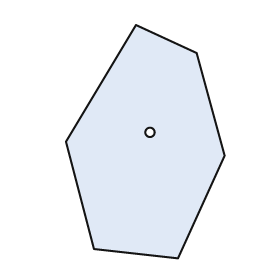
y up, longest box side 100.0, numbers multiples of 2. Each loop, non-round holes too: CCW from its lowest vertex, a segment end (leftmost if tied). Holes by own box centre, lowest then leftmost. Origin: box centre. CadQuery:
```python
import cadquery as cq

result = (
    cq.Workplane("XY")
    .moveTo(14.0, -50.0)
    .lineTo(34.0, -6.0)
    .lineTo(22.0, 38.0)
    .lineTo(-4.0, 50.0)
    .lineTo(-34.0, 0.0)
    .lineTo(-22.0, -46.0)
    .close()
    .moveTo(2.0, 4.0)
    .circle(2.0)
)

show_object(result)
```